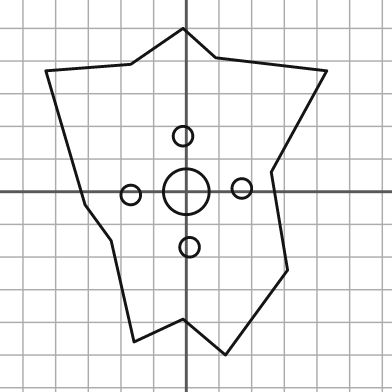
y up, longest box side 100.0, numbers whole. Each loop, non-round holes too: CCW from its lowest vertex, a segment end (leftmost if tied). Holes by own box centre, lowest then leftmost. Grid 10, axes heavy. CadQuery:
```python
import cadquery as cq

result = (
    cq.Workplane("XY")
    .moveTo(12.0, -50.0)
    .lineTo(31.0, -24.0)
    .lineTo(26.0, 6.0)
    .lineTo(43.0, 37.0)
    .lineTo(9.0, 41.0)
    .lineTo(-1.0, 50.0)
    .lineTo(-17.0, 39.0)
    .lineTo(-43.0, 37.0)
    .lineTo(-31.0, -4.0)
    .lineTo(-23.0, -15.0)
    .lineTo(-16.0, -46.0)
    .lineTo(-1.0, -39.0)
    .close()
    .moveTo(1.0, -17.0)
    .circle(3.0)
    .moveTo(-17.0, -1.0)
    .circle(3.0)
    .moveTo(0.0, 0.0)
    .circle(7.0)
    .moveTo(17.0, 1.0)
    .circle(3.0)
    .moveTo(-1.0, 17.0)
    .circle(3.0)
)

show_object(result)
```